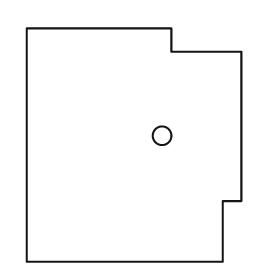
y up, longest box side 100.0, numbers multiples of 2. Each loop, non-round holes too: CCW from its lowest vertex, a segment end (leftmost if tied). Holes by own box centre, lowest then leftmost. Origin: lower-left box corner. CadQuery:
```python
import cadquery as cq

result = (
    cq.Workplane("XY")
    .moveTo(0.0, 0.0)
    .lineTo(84.0, 0.0)
    .lineTo(84.0, 26.0)
    .lineTo(92.0, 26.0)
    .lineTo(92.0, 90.0)
    .lineTo(62.0, 90.0)
    .lineTo(62.0, 100.0)
    .lineTo(0.0, 100.0)
    .close()
    .moveTo(58.0, 54.0)
    .circle(4.0)
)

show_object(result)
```